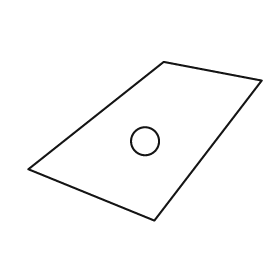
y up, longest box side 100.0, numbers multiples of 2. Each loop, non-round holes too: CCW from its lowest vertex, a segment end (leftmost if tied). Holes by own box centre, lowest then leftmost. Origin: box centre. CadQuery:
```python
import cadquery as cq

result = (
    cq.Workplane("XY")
    .moveTo(4.0, -34.0)
    .lineTo(50.0, 26.0)
    .lineTo(8.0, 34.0)
    .lineTo(-50.0, -12.0)
    .close()
    .moveTo(0.0, 0.0)
    .circle(6.0)
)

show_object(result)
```